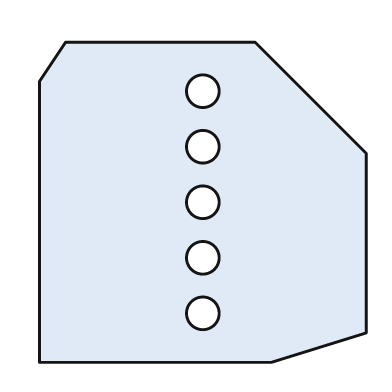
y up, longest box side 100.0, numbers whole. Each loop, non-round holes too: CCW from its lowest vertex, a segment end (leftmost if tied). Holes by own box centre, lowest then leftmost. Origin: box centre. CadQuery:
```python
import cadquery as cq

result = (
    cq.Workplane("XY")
    .moveTo(-50.0, -49.0)
    .lineTo(21.0, -49.0)
    .lineTo(50.0, -40.0)
    .lineTo(50.0, 15.0)
    .lineTo(16.0, 49.0)
    .lineTo(-42.0, 49.0)
    .lineTo(-50.0, 37.0)
    .close()
    .moveTo(0.0, -34.0)
    .circle(5.0)
    .moveTo(0.0, -17.0)
    .circle(5.0)
    .moveTo(0.0, 0.0)
    .circle(5.0)
    .moveTo(0.0, 17.0)
    .circle(5.0)
    .moveTo(0.0, 34.0)
    .circle(5.0)
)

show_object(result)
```